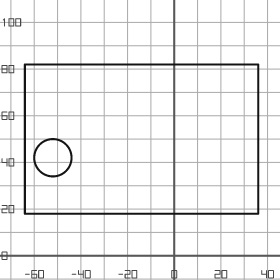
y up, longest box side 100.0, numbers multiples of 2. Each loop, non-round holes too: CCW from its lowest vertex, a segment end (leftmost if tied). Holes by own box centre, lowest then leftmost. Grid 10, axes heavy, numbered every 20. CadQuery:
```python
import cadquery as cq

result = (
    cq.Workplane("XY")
    .moveTo(-64.0, 18.0)
    .lineTo(36.0, 18.0)
    .lineTo(36.0, 82.0)
    .lineTo(-64.0, 82.0)
    .close()
    .moveTo(-52.0, 42.0)
    .circle(8.0)
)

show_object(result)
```